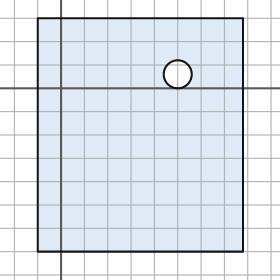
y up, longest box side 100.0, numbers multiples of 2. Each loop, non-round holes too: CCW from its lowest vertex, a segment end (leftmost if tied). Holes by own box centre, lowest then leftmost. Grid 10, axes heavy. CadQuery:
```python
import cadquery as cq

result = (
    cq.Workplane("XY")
    .moveTo(-10.0, -70.0)
    .lineTo(78.0, -70.0)
    .lineTo(78.0, 30.0)
    .lineTo(-10.0, 30.0)
    .close()
    .moveTo(50.0, 6.0)
    .circle(6.0)
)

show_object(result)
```